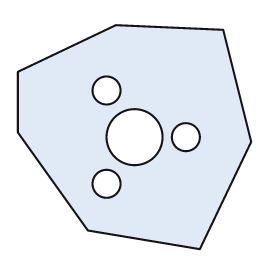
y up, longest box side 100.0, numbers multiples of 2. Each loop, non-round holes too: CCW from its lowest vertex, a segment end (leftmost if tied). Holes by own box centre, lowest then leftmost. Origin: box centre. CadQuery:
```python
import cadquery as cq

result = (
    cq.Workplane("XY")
    .moveTo(28.0, -48.0)
    .lineTo(50.0, -2.0)
    .lineTo(38.0, 46.0)
    .lineTo(-8.0, 48.0)
    .lineTo(-50.0, 28.0)
    .lineTo(-50.0, 2.0)
    .lineTo(-20.0, -40.0)
    .close()
    .moveTo(-12.0, -20.0)
    .circle(6.0)
    .moveTo(0.0, 0.0)
    .circle(12.0)
    .moveTo(22.0, 0.0)
    .circle(6.0)
    .moveTo(-12.0, 20.0)
    .circle(6.0)
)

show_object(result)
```